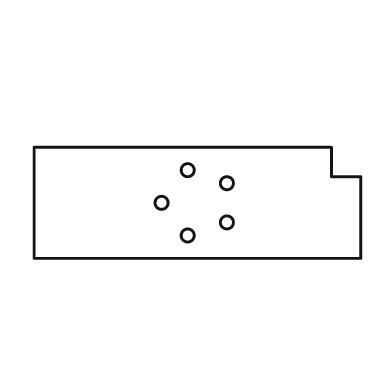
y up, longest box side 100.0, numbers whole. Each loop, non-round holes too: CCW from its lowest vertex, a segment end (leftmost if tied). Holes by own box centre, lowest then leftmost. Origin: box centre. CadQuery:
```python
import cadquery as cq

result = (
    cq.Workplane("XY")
    .moveTo(-50.0, -17.0)
    .lineTo(50.0, -17.0)
    .lineTo(50.0, 8.0)
    .lineTo(41.0, 8.0)
    .lineTo(41.0, 17.0)
    .lineTo(-50.0, 17.0)
    .close()
    .moveTo(-3.0, -10.0)
    .circle(2.0)
    .moveTo(9.0, -6.0)
    .circle(2.0)
    .moveTo(-11.0, 0.0)
    .circle(2.0)
    .moveTo(9.0, 6.0)
    .circle(2.0)
    .moveTo(-3.0, 10.0)
    .circle(2.0)
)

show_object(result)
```